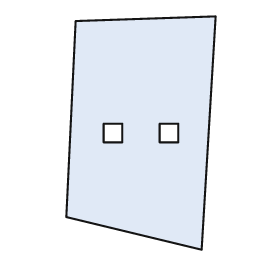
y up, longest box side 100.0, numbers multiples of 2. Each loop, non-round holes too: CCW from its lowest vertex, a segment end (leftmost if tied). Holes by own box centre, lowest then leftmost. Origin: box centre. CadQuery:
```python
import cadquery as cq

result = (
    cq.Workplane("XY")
    .moveTo(26.0, -50.0)
    .lineTo(32.0, 50.0)
    .lineTo(-28.0, 48.0)
    .lineTo(-32.0, -36.0)
    .close()
    .moveTo(-16.0, -4.0)
    .lineTo(-8.0, -4.0)
    .lineTo(-8.0, 4.0)
    .lineTo(-16.0, 4.0)
    .close()
    .moveTo(8.0, -4.0)
    .lineTo(16.0, -4.0)
    .lineTo(16.0, 4.0)
    .lineTo(8.0, 4.0)
    .close()
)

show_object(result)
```